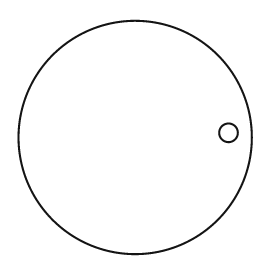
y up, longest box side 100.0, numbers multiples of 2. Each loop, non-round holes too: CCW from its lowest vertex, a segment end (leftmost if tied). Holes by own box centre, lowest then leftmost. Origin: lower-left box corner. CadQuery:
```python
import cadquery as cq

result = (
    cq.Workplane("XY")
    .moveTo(50.0, 50.0)
    .circle(50.0)
    .moveTo(90.0, 52.0)
    .circle(4.0)
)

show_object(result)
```